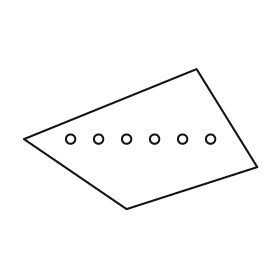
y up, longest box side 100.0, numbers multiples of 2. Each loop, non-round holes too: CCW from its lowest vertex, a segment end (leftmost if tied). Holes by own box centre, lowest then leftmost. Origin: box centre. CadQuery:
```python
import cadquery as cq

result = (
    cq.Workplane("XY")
    .moveTo(-6.0, -30.0)
    .lineTo(50.0, -12.0)
    .lineTo(24.0, 30.0)
    .lineTo(-50.0, 0.0)
    .close()
    .moveTo(-30.0, 0.0)
    .circle(2.0)
    .moveTo(-18.0, 0.0)
    .circle(2.0)
    .moveTo(-6.0, 0.0)
    .circle(2.0)
    .moveTo(6.0, 0.0)
    .circle(2.0)
    .moveTo(18.0, 0.0)
    .circle(2.0)
    .moveTo(30.0, 0.0)
    .circle(2.0)
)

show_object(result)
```